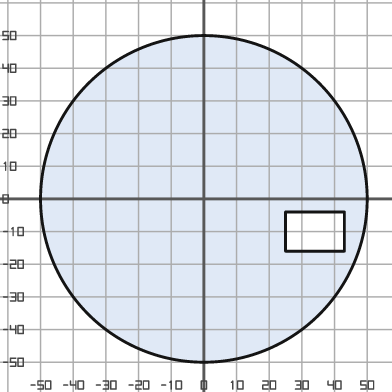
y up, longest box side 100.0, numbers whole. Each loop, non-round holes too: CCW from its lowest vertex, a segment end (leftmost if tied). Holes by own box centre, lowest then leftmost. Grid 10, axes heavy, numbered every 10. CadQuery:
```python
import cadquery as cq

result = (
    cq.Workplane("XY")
    .moveTo(0.0, 0.0)
    .circle(50.0)
    .moveTo(25.0, -16.0)
    .lineTo(43.0, -16.0)
    .lineTo(43.0, -4.0)
    .lineTo(25.0, -4.0)
    .close()
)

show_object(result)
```